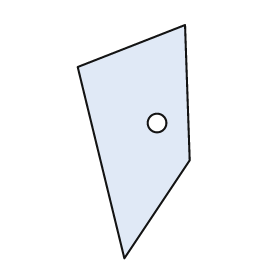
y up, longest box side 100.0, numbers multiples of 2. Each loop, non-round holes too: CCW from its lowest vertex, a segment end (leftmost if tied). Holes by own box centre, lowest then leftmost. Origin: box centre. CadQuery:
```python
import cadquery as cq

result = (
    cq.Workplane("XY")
    .moveTo(-4.0, -50.0)
    .lineTo(24.0, -8.0)
    .lineTo(22.0, 50.0)
    .lineTo(-24.0, 32.0)
    .close()
    .moveTo(10.0, 8.0)
    .circle(4.0)
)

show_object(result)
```